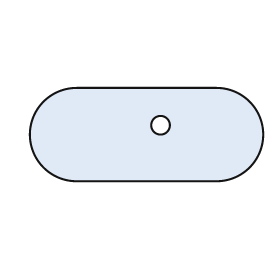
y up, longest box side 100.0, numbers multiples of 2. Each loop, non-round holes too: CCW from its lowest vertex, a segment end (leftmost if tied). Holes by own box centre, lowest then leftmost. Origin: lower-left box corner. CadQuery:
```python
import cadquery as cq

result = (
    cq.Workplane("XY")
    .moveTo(20.0, 0.0)
    .lineTo(80.0, 0.0)
    .threePointArc((100.0, 20.0), (80.0, 40.0))
    .lineTo(20.0, 40.0)
    .threePointArc((0.0, 20.0), (20.0, 0.0))
    .close()
    .moveTo(56.0, 24.0)
    .circle(4.0)
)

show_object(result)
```